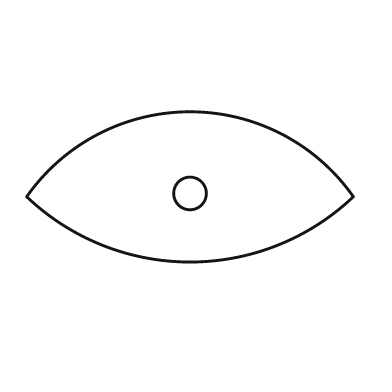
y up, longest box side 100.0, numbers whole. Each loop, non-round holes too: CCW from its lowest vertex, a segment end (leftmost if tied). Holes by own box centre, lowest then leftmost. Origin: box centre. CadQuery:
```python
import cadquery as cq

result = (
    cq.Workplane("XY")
    .moveTo(-50.0, -3.0)
    .threePointArc((0.0, -23.0), (50.0, -3.0))
    .threePointArc((0.0, 23.0), (-50.0, -3.0))
    .close()
    .moveTo(0.0, -2.0)
    .circle(5.0)
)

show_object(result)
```